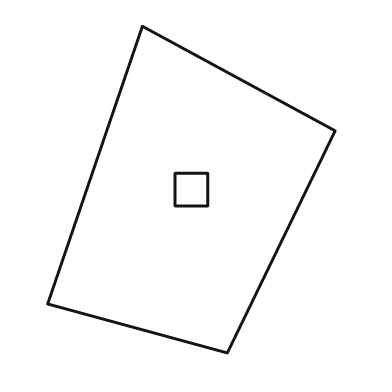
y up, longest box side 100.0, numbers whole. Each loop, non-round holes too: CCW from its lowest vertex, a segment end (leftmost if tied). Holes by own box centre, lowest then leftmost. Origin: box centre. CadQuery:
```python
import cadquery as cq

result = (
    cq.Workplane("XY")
    .moveTo(11.0, -50.0)
    .lineTo(44.0, 18.0)
    .lineTo(-15.0, 50.0)
    .lineTo(-44.0, -35.0)
    .close()
    .moveTo(-5.0, -5.0)
    .lineTo(5.0, -5.0)
    .lineTo(5.0, 5.0)
    .lineTo(-5.0, 5.0)
    .close()
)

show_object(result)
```